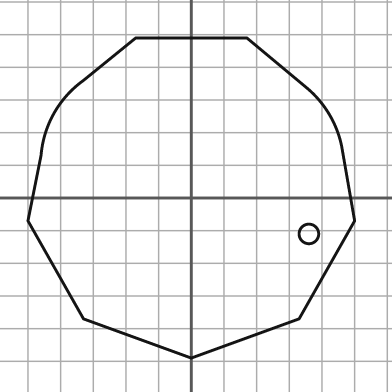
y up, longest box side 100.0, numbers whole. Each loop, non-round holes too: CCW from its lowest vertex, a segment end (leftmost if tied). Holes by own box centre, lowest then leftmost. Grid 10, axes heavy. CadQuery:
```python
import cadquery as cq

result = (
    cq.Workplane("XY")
    .moveTo(0.0, -49.0)
    .lineTo(33.0, -37.0)
    .lineTo(50.0, -7.0)
    .lineTo(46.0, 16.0)
    .threePointArc((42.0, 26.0), (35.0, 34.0))
    .lineTo(17.0, 49.0)
    .lineTo(-17.0, 49.0)
    .lineTo(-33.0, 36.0)
    .threePointArc((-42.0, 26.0), (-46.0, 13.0))
    .lineTo(-50.0, -7.0)
    .lineTo(-33.0, -37.0)
    .close()
    .moveTo(36.0, -11.0)
    .circle(3.0)
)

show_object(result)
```